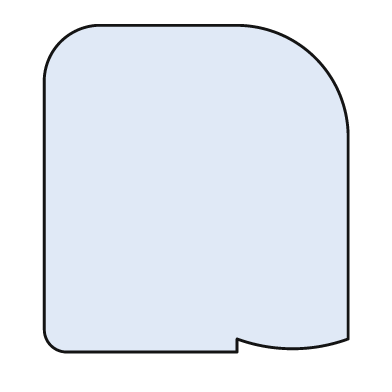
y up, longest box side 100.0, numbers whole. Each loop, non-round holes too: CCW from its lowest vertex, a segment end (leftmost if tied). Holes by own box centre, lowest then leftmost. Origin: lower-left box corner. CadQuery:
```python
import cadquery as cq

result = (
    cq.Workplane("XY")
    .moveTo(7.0, 0.0)
    .lineTo(59.0, 0.0)
    .lineTo(59.0, 4.0)
    .threePointArc((76.0, 1.0), (93.0, 4.0))
    .lineTo(93.0, 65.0)
    .threePointArc((83.0, 90.0), (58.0, 100.0))
    .lineTo(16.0, 100.0)
    .threePointArc((5.0, 95.0), (0.0, 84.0))
    .lineTo(0.0, 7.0)
    .threePointArc((2.0, 2.0), (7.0, 0.0))
    .close()
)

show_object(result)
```